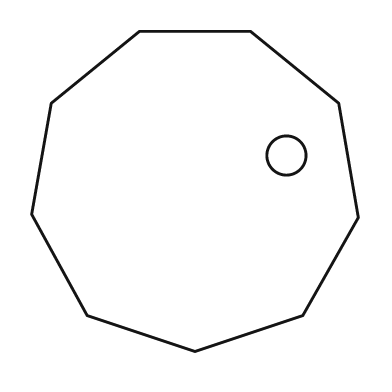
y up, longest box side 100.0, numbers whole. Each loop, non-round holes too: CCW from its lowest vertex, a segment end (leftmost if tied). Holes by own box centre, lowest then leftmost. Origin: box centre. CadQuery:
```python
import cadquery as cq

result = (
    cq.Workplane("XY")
    .moveTo(0.0, -49.0)
    .lineTo(33.0, -38.0)
    .lineTo(50.0, -8.0)
    .lineTo(44.0, 27.0)
    .lineTo(17.0, 49.0)
    .lineTo(-17.0, 49.0)
    .lineTo(-44.0, 27.0)
    .lineTo(-50.0, -7.0)
    .lineTo(-33.0, -38.0)
    .close()
    .moveTo(28.0, 11.0)
    .circle(6.0)
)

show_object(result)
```